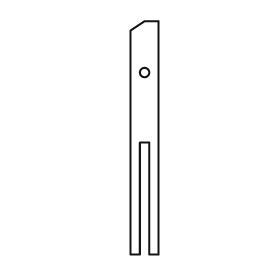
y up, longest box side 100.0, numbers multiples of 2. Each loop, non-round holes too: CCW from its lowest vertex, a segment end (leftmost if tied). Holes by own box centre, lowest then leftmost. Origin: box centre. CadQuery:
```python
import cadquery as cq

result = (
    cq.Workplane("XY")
    .moveTo(-6.0, -50.0)
    .lineTo(-2.0, -50.0)
    .lineTo(-2.0, -2.0)
    .lineTo(2.0, -2.0)
    .lineTo(2.0, -50.0)
    .lineTo(6.0, -50.0)
    .lineTo(6.0, 50.0)
    .lineTo(0.0, 50.0)
    .lineTo(-6.0, 46.0)
    .close()
    .moveTo(0.0, 28.0)
    .circle(2.0)
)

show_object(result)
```